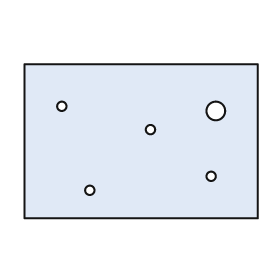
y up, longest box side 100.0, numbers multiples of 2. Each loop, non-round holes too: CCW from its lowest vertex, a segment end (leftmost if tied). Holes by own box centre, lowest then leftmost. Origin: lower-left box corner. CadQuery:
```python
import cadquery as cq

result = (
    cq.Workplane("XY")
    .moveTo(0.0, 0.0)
    .lineTo(100.0, 0.0)
    .lineTo(100.0, 66.0)
    .lineTo(0.0, 66.0)
    .close()
    .moveTo(28.0, 12.0)
    .circle(2.0)
    .moveTo(80.0, 18.0)
    .circle(2.0)
    .moveTo(54.0, 38.0)
    .circle(2.0)
    .moveTo(82.0, 46.0)
    .circle(4.0)
    .moveTo(16.0, 48.0)
    .circle(2.0)
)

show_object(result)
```